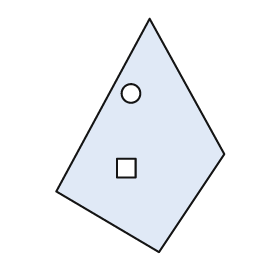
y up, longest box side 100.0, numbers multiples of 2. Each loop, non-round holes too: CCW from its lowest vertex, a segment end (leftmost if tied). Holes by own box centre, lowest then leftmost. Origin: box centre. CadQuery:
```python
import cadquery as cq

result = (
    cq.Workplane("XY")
    .moveTo(8.0, -50.0)
    .lineTo(36.0, -8.0)
    .lineTo(4.0, 50.0)
    .lineTo(-36.0, -24.0)
    .close()
    .moveTo(-10.0, -18.0)
    .lineTo(-2.0, -18.0)
    .lineTo(-2.0, -10.0)
    .lineTo(-10.0, -10.0)
    .close()
    .moveTo(-4.0, 18.0)
    .circle(4.0)
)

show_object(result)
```